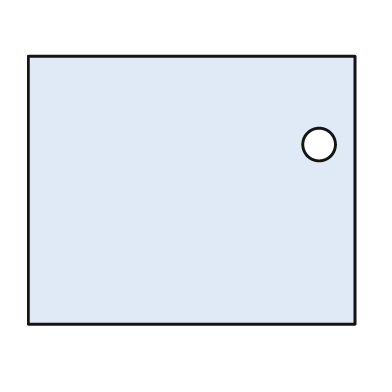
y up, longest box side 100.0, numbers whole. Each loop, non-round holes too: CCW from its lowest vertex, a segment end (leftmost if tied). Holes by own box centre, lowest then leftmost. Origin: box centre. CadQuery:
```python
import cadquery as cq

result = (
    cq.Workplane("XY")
    .moveTo(-50.0, -41.0)
    .lineTo(50.0, -41.0)
    .lineTo(50.0, 41.0)
    .lineTo(-50.0, 41.0)
    .close()
    .moveTo(39.0, 14.0)
    .circle(5.0)
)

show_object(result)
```